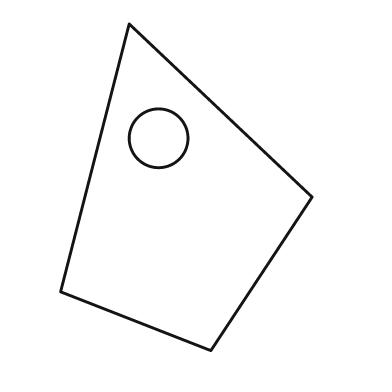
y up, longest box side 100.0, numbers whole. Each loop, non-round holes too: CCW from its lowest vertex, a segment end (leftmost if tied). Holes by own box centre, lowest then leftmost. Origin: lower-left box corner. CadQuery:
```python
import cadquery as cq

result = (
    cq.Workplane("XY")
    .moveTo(46.0, 0.0)
    .lineTo(77.0, 47.0)
    .lineTo(21.0, 100.0)
    .lineTo(0.0, 18.0)
    .close()
    .moveTo(30.0, 65.0)
    .circle(9.0)
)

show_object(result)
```